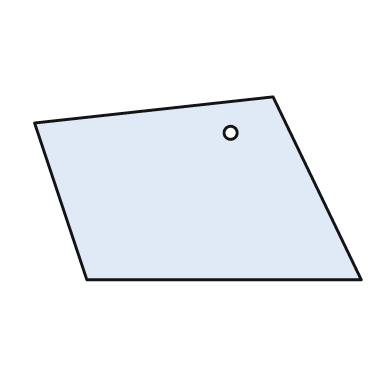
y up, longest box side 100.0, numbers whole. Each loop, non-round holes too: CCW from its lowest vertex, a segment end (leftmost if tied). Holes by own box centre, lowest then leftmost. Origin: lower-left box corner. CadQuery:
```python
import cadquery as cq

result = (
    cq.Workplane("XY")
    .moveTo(16.0, 0.0)
    .lineTo(100.0, 0.0)
    .lineTo(73.0, 56.0)
    .lineTo(0.0, 48.0)
    .close()
    .moveTo(60.0, 45.0)
    .circle(2.0)
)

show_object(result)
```